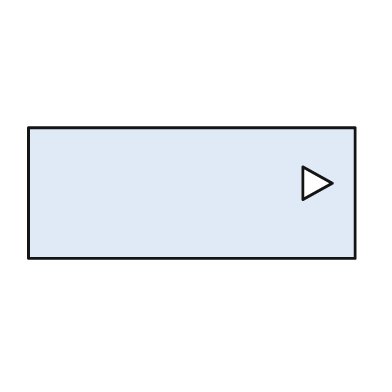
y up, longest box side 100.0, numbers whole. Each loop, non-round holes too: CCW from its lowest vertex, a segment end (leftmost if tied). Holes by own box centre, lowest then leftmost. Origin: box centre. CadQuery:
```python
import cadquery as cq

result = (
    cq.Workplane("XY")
    .moveTo(-50.0, -20.0)
    .lineTo(50.0, -20.0)
    .lineTo(50.0, 20.0)
    .lineTo(-50.0, 20.0)
    .close()
    .moveTo(34.0, -2.0)
    .lineTo(43.0, 3.0)
    .lineTo(34.0, 8.0)
    .close()
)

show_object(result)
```